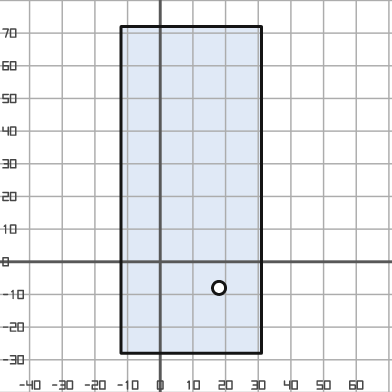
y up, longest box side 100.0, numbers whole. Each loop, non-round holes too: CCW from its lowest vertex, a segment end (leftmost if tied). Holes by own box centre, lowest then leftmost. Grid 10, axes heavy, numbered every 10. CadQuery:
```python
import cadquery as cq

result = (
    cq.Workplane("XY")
    .moveTo(-12.0, -28.0)
    .lineTo(31.0, -28.0)
    .lineTo(31.0, 72.0)
    .lineTo(-12.0, 72.0)
    .close()
    .moveTo(18.0, -8.0)
    .circle(2.0)
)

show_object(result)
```